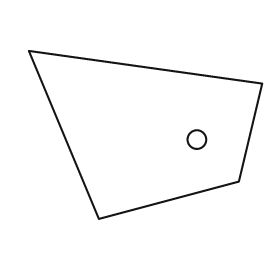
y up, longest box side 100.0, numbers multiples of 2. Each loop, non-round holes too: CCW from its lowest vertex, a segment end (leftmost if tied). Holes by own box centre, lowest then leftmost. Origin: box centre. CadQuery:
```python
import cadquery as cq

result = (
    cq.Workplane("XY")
    .moveTo(-20.0, -36.0)
    .lineTo(40.0, -20.0)
    .lineTo(50.0, 22.0)
    .lineTo(-50.0, 36.0)
    .close()
    .moveTo(22.0, -2.0)
    .circle(4.0)
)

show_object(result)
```